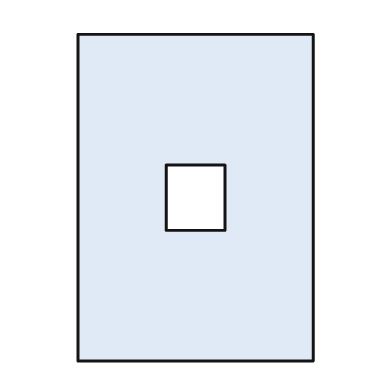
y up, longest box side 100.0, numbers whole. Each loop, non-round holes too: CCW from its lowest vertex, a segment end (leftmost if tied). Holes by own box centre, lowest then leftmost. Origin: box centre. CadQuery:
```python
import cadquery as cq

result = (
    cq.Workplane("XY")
    .moveTo(-36.0, -50.0)
    .lineTo(36.0, -50.0)
    .lineTo(36.0, 50.0)
    .lineTo(-36.0, 50.0)
    .close()
    .moveTo(-9.0, -10.0)
    .lineTo(9.0, -10.0)
    .lineTo(9.0, 10.0)
    .lineTo(-9.0, 10.0)
    .close()
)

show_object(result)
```